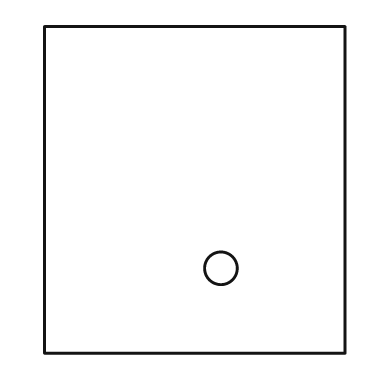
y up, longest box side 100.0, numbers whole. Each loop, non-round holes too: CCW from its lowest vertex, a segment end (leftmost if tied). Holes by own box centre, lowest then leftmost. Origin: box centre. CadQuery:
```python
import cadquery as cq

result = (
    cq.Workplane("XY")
    .moveTo(-46.0, -50.0)
    .lineTo(46.0, -50.0)
    .lineTo(46.0, 50.0)
    .lineTo(-46.0, 50.0)
    .close()
    .moveTo(8.0, -24.0)
    .circle(5.0)
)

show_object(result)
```